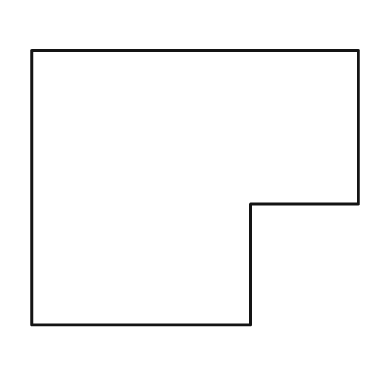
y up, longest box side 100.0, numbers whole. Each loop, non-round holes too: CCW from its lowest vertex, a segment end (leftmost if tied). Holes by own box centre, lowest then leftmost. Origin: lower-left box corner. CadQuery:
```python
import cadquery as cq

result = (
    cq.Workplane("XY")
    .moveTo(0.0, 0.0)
    .lineTo(67.0, 0.0)
    .lineTo(67.0, 37.0)
    .lineTo(100.0, 37.0)
    .lineTo(100.0, 84.0)
    .lineTo(0.0, 84.0)
    .close()
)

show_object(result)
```